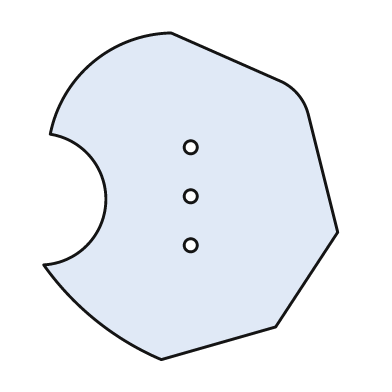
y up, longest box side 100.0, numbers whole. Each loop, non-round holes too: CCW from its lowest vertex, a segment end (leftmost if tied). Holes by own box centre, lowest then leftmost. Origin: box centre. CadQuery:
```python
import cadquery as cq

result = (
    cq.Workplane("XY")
    .moveTo(-9.0, -50.0)
    .lineTo(26.0, -40.0)
    .lineTo(45.0, -11.0)
    .lineTo(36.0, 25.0)
    .threePointArc((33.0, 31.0), (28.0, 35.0))
    .lineTo(-6.0, 50.0)
    .threePointArc((-30.0, 41.0), (-43.0, 19.0))
    .threePointArc((-26.0, -2.0), (-45.0, -21.0))
    .threePointArc((-29.0, -38.0), (-9.0, -50.0))
    .close()
    .moveTo(0.0, -15.0)
    .circle(2.0)
    .moveTo(0.0, 0.0)
    .circle(2.0)
    .moveTo(0.0, 15.0)
    .circle(2.0)
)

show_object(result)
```